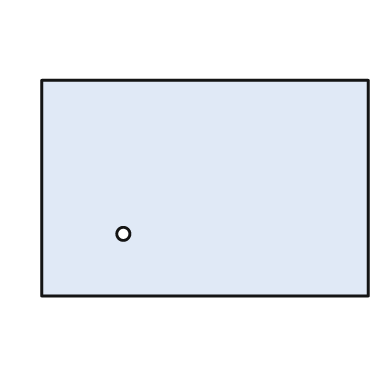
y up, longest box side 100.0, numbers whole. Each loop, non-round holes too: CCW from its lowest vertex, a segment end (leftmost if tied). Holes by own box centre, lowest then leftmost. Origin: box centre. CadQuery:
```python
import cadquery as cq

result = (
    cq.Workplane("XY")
    .moveTo(-50.0, -33.0)
    .lineTo(50.0, -33.0)
    .lineTo(50.0, 33.0)
    .lineTo(-50.0, 33.0)
    .close()
    .moveTo(-25.0, -14.0)
    .circle(2.0)
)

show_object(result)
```